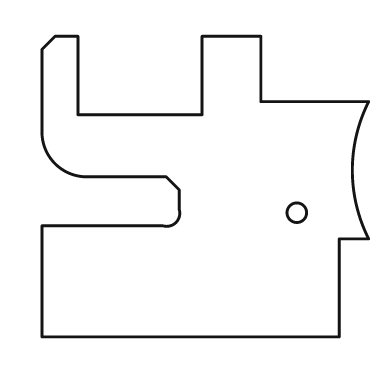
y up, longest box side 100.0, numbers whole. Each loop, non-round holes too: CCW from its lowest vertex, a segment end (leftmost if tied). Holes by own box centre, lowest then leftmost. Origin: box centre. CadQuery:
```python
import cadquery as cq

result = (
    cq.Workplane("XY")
    .moveTo(-50.0, -46.0)
    .lineTo(41.0, -46.0)
    .lineTo(41.0, -16.0)
    .lineTo(50.0, -16.0)
    .threePointArc((45.0, 5.0), (50.0, 26.0))
    .lineTo(17.0, 26.0)
    .lineTo(17.0, 46.0)
    .lineTo(-1.0, 46.0)
    .lineTo(-1.0, 22.0)
    .lineTo(-39.0, 22.0)
    .lineTo(-39.0, 46.0)
    .lineTo(-46.0, 46.0)
    .lineTo(-50.0, 42.0)
    .lineTo(-50.0, 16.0)
    .threePointArc((-46.0, 7.0), (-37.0, 3.0))
    .lineTo(-12.0, 3.0)
    .lineTo(-8.0, -1.0)
    .lineTo(-8.0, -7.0)
    .threePointArc((-9.0, -11.0), (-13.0, -12.0))
    .lineTo(-50.0, -12.0)
    .close()
    .moveTo(28.0, -8.0)
    .circle(3.0)
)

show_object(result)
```